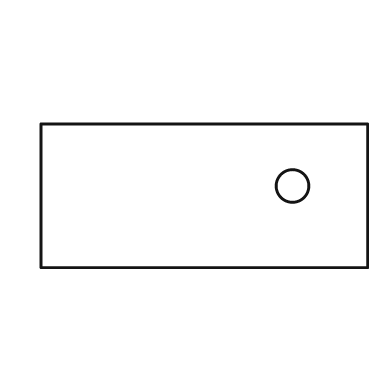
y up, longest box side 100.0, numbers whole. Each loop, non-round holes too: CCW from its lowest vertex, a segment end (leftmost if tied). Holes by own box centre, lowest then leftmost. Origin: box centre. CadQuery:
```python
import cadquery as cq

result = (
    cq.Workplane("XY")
    .moveTo(-50.0, -22.0)
    .lineTo(50.0, -22.0)
    .lineTo(50.0, 22.0)
    .lineTo(-50.0, 22.0)
    .close()
    .moveTo(27.0, 3.0)
    .circle(5.0)
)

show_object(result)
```